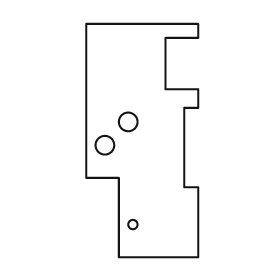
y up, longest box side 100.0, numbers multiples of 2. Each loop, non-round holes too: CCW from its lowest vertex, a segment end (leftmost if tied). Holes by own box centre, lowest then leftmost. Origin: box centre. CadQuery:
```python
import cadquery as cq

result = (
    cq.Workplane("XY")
    .moveTo(-10.0, -50.0)
    .lineTo(24.0, -50.0)
    .lineTo(24.0, -20.0)
    .lineTo(18.0, -20.0)
    .lineTo(18.0, 14.0)
    .lineTo(24.0, 14.0)
    .lineTo(24.0, 22.0)
    .lineTo(10.0, 22.0)
    .lineTo(10.0, 44.0)
    .lineTo(24.0, 44.0)
    .lineTo(24.0, 50.0)
    .lineTo(-24.0, 50.0)
    .lineTo(-24.0, -16.0)
    .lineTo(-10.0, -16.0)
    .close()
    .moveTo(-4.0, -36.0)
    .circle(2.0)
    .moveTo(-16.0, -2.0)
    .circle(4.0)
    .moveTo(-6.0, 8.0)
    .circle(4.0)
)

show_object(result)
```